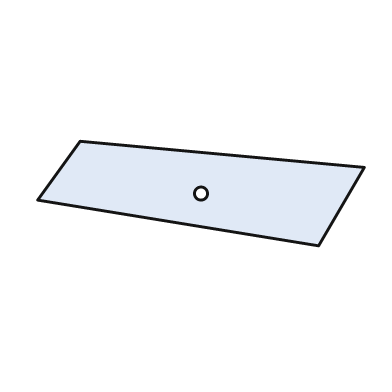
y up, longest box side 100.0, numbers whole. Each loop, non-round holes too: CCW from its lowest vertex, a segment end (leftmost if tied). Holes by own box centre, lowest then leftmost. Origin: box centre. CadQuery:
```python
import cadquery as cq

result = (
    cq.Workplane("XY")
    .moveTo(36.0, -16.0)
    .lineTo(50.0, 8.0)
    .lineTo(-37.0, 16.0)
    .lineTo(-50.0, -2.0)
    .close()
    .moveTo(0.0, 0.0)
    .circle(2.0)
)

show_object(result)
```